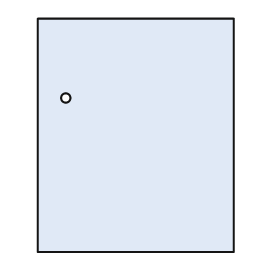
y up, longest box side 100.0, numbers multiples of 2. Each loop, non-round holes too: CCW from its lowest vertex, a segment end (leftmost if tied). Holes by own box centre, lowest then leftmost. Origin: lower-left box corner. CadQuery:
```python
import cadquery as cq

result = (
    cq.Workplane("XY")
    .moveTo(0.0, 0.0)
    .lineTo(84.0, 0.0)
    .lineTo(84.0, 100.0)
    .lineTo(0.0, 100.0)
    .close()
    .moveTo(12.0, 66.0)
    .circle(2.0)
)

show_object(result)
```